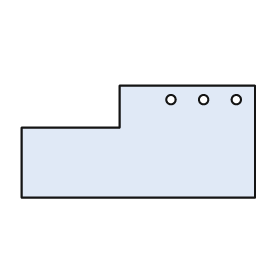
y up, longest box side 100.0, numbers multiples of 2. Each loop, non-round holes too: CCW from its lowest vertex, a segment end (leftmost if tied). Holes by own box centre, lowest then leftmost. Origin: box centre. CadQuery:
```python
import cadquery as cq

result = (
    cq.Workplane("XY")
    .moveTo(-50.0, -24.0)
    .lineTo(50.0, -24.0)
    .lineTo(50.0, 24.0)
    .lineTo(-8.0, 24.0)
    .lineTo(-8.0, 6.0)
    .lineTo(-50.0, 6.0)
    .close()
    .moveTo(14.0, 18.0)
    .circle(2.0)
    .moveTo(28.0, 18.0)
    .circle(2.0)
    .moveTo(42.0, 18.0)
    .circle(2.0)
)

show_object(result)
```